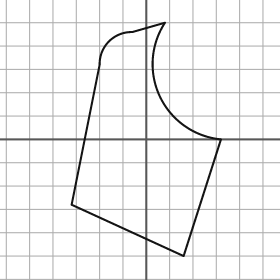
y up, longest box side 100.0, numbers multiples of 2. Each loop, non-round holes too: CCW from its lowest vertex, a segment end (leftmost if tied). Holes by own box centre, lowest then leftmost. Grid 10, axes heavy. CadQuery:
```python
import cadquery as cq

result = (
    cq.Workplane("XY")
    .moveTo(16.0, -50.0)
    .lineTo(32.0, 0.0)
    .threePointArc((6.0, 18.0), (8.0, 50.0))
    .lineTo(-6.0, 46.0)
    .threePointArc((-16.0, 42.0), (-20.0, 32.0))
    .lineTo(-32.0, -28.0)
    .close()
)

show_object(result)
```